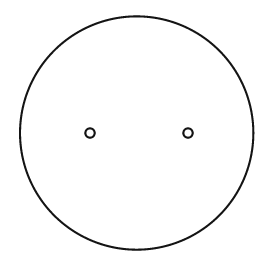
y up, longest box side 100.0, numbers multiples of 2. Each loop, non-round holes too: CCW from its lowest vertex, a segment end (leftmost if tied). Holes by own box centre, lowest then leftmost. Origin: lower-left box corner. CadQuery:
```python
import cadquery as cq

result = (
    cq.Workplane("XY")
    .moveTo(50.0, 50.0)
    .circle(50.0)
    .moveTo(30.0, 50.0)
    .circle(2.0)
    .moveTo(72.0, 50.0)
    .circle(2.0)
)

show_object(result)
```